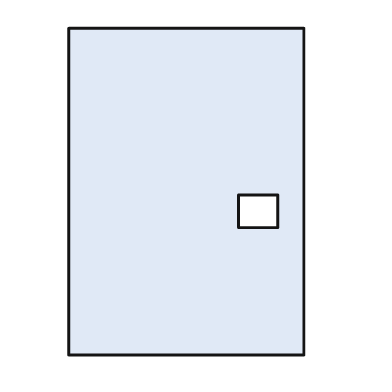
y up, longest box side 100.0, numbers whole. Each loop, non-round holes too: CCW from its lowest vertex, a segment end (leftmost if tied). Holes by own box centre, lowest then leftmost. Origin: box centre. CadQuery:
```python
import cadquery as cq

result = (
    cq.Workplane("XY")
    .moveTo(-36.0, -50.0)
    .lineTo(36.0, -50.0)
    .lineTo(36.0, 50.0)
    .lineTo(-36.0, 50.0)
    .close()
    .moveTo(16.0, -11.0)
    .lineTo(28.0, -11.0)
    .lineTo(28.0, -1.0)
    .lineTo(16.0, -1.0)
    .close()
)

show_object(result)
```